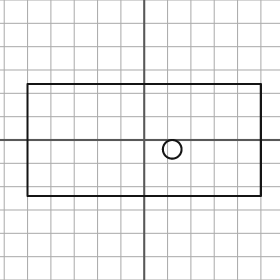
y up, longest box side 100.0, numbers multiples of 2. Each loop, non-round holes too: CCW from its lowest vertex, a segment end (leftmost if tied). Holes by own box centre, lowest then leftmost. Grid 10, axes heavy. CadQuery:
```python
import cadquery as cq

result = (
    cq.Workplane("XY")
    .moveTo(-50.0, -24.0)
    .lineTo(50.0, -24.0)
    .lineTo(50.0, 24.0)
    .lineTo(-50.0, 24.0)
    .close()
    .moveTo(12.0, -4.0)
    .circle(4.0)
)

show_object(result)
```